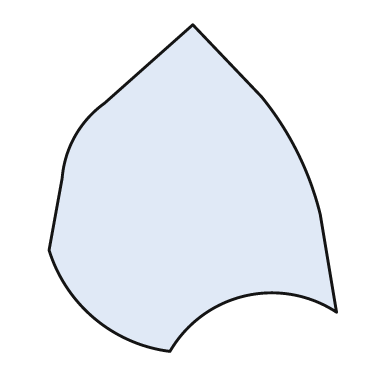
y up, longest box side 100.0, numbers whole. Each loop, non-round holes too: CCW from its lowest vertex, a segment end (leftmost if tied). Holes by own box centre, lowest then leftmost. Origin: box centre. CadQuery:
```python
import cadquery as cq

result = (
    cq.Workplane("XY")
    .moveTo(-7.0, -50.0)
    .threePointArc((16.0, -33.0), (44.0, -38.0))
    .lineTo(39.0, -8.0)
    .threePointArc((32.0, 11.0), (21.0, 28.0))
    .lineTo(0.0, 50.0)
    .lineTo(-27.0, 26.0)
    .threePointArc((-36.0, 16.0), (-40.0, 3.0))
    .lineTo(-44.0, -19.0)
    .threePointArc((-30.0, -40.0), (-7.0, -50.0))
    .close()
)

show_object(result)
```